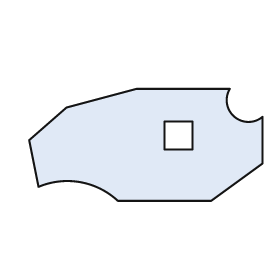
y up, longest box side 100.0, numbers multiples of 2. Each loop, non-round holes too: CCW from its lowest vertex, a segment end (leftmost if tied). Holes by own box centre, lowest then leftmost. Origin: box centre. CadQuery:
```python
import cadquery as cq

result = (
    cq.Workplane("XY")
    .moveTo(-12.0, -24.0)
    .lineTo(28.0, -24.0)
    .lineTo(50.0, -8.0)
    .lineTo(50.0, 12.0)
    .threePointArc((38.0, 12.0), (36.0, 24.0))
    .lineTo(-4.0, 24.0)
    .lineTo(-34.0, 16.0)
    .lineTo(-50.0, 2.0)
    .lineTo(-46.0, -18.0)
    .threePointArc((-28.0, -16.0), (-12.0, -24.0))
    .close()
    .moveTo(8.0, -2.0)
    .lineTo(20.0, -2.0)
    .lineTo(20.0, 10.0)
    .lineTo(8.0, 10.0)
    .close()
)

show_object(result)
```